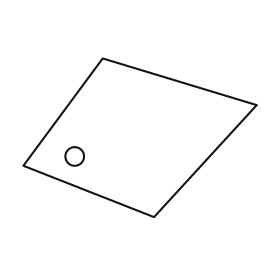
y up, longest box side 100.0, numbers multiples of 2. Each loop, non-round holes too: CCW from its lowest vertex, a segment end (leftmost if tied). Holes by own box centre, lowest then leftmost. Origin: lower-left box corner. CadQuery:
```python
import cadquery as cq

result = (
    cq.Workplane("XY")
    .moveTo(56.0, 0.0)
    .lineTo(100.0, 48.0)
    .lineTo(34.0, 68.0)
    .lineTo(0.0, 22.0)
    .close()
    .moveTo(22.0, 26.0)
    .circle(4.0)
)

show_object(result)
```